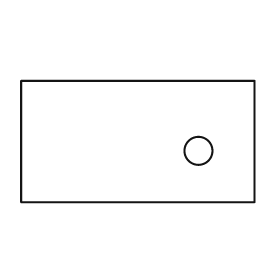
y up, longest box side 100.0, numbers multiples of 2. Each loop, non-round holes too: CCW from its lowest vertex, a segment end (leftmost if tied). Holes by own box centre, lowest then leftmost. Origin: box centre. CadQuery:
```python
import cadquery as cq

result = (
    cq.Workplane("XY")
    .moveTo(-50.0, -26.0)
    .lineTo(50.0, -26.0)
    .lineTo(50.0, 26.0)
    .lineTo(-50.0, 26.0)
    .close()
    .moveTo(26.0, -4.0)
    .circle(6.0)
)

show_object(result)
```